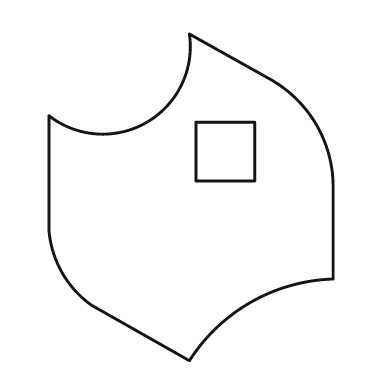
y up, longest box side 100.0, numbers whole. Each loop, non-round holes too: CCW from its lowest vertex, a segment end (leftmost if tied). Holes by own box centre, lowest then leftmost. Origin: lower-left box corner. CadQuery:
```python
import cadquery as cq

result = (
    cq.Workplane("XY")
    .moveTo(43.0, 0.0)
    .threePointArc((62.0, 18.0), (87.0, 25.0))
    .lineTo(87.0, 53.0)
    .threePointArc((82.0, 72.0), (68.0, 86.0))
    .lineTo(43.0, 100.0)
    .threePointArc((30.0, 73.0), (0.0, 75.0))
    .lineTo(0.0, 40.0)
    .threePointArc((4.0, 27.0), (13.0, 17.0))
    .close()
    .moveTo(45.0, 55.0)
    .lineTo(63.0, 55.0)
    .lineTo(63.0, 73.0)
    .lineTo(45.0, 73.0)
    .close()
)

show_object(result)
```